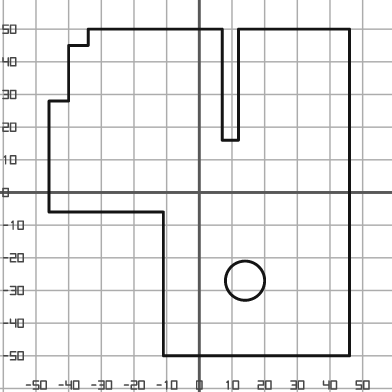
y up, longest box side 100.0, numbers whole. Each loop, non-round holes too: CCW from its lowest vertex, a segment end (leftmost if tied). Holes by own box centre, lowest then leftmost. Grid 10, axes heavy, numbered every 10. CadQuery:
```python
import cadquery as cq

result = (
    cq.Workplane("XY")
    .moveTo(-11.0, -50.0)
    .lineTo(46.0, -50.0)
    .lineTo(46.0, 50.0)
    .lineTo(12.0, 50.0)
    .lineTo(12.0, 16.0)
    .lineTo(7.0, 16.0)
    .lineTo(7.0, 50.0)
    .lineTo(-34.0, 50.0)
    .lineTo(-34.0, 45.0)
    .lineTo(-40.0, 45.0)
    .lineTo(-40.0, 28.0)
    .lineTo(-46.0, 28.0)
    .lineTo(-46.0, -6.0)
    .lineTo(-11.0, -6.0)
    .close()
    .moveTo(14.0, -27.0)
    .circle(6.0)
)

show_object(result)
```